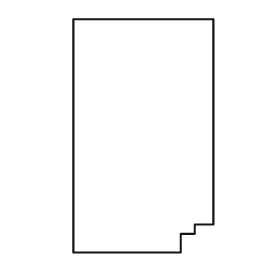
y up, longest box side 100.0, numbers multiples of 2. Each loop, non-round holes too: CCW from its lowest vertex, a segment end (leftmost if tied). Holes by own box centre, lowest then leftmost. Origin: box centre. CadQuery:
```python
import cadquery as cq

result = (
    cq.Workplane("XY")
    .moveTo(-30.0, -50.0)
    .lineTo(16.0, -50.0)
    .lineTo(16.0, -42.0)
    .lineTo(22.0, -42.0)
    .lineTo(22.0, -38.0)
    .lineTo(30.0, -38.0)
    .lineTo(30.0, 50.0)
    .lineTo(-30.0, 50.0)
    .close()
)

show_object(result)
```